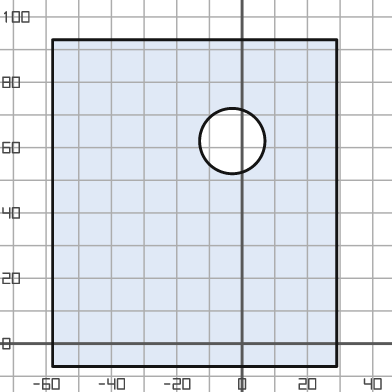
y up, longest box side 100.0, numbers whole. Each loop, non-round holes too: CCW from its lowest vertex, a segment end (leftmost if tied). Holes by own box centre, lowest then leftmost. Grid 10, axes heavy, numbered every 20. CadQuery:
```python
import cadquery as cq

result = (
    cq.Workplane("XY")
    .moveTo(-58.0, -7.0)
    .lineTo(29.0, -7.0)
    .lineTo(29.0, 93.0)
    .lineTo(-58.0, 93.0)
    .close()
    .moveTo(-3.0, 62.0)
    .circle(10.0)
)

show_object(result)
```